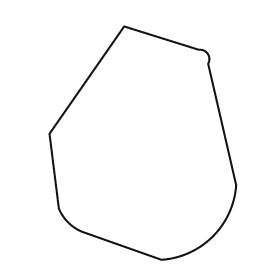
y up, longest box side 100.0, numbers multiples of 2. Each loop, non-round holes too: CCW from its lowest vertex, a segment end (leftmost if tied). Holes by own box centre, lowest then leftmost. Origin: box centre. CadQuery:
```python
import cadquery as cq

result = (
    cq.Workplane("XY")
    .moveTo(8.0, -50.0)
    .threePointArc((30.0, -40.0), (40.0, -18.0))
    .lineTo(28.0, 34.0)
    .threePointArc((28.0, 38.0), (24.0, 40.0))
    .lineTo(-8.0, 50.0)
    .lineTo(-40.0, 4.0)
    .lineTo(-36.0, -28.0)
    .threePointArc((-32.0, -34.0), (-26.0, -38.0))
    .close()
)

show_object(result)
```